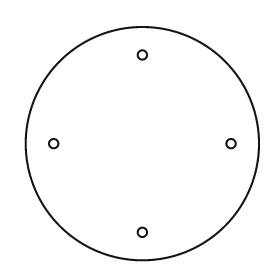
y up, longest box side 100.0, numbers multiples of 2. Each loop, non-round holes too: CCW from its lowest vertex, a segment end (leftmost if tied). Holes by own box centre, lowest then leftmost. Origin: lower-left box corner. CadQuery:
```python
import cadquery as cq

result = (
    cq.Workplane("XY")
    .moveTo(50.0, 50.0)
    .circle(50.0)
    .moveTo(50.0, 12.0)
    .circle(2.0)
    .moveTo(12.0, 50.0)
    .circle(2.0)
    .moveTo(88.0, 50.0)
    .circle(2.0)
    .moveTo(50.0, 88.0)
    .circle(2.0)
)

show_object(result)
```